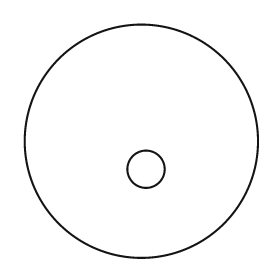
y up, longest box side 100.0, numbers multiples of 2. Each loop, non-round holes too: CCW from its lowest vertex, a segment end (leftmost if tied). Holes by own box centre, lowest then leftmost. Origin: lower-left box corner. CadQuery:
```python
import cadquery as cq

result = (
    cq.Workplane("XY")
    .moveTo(50.0, 50.0)
    .circle(50.0)
    .moveTo(52.0, 38.0)
    .circle(8.0)
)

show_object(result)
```